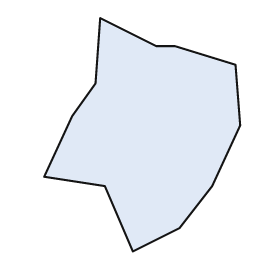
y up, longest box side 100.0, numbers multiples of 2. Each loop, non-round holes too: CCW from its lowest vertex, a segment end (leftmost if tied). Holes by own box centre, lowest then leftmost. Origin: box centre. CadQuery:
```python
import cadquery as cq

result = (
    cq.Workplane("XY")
    .moveTo(-4.0, -50.0)
    .lineTo(16.0, -40.0)
    .lineTo(30.0, -22.0)
    .lineTo(42.0, 4.0)
    .lineTo(40.0, 30.0)
    .lineTo(14.0, 38.0)
    .lineTo(6.0, 38.0)
    .lineTo(-18.0, 50.0)
    .lineTo(-20.0, 22.0)
    .lineTo(-30.0, 8.0)
    .lineTo(-42.0, -18.0)
    .lineTo(-16.0, -22.0)
    .close()
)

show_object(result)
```